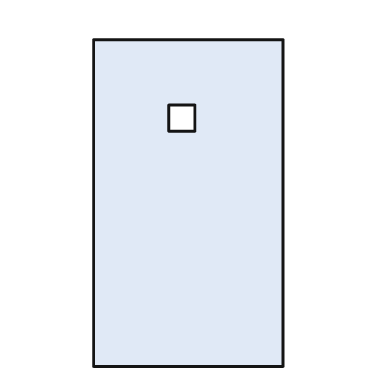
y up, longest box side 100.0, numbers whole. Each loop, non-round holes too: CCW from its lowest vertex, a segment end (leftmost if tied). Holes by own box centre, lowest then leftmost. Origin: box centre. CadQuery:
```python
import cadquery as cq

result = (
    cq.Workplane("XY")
    .moveTo(-29.0, -50.0)
    .lineTo(29.0, -50.0)
    .lineTo(29.0, 50.0)
    .lineTo(-29.0, 50.0)
    .close()
    .moveTo(-6.0, 22.0)
    .lineTo(2.0, 22.0)
    .lineTo(2.0, 30.0)
    .lineTo(-6.0, 30.0)
    .close()
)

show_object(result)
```